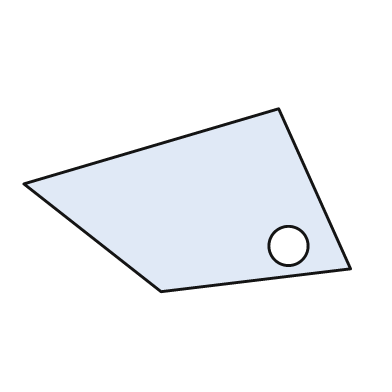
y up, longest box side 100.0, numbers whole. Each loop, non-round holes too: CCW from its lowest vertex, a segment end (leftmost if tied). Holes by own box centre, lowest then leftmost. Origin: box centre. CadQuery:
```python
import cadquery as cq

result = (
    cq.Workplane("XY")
    .moveTo(-8.0, -28.0)
    .lineTo(50.0, -21.0)
    .lineTo(28.0, 28.0)
    .lineTo(-50.0, 5.0)
    .close()
    .moveTo(31.0, -14.0)
    .circle(6.0)
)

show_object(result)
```